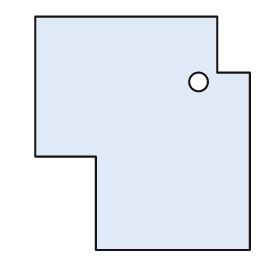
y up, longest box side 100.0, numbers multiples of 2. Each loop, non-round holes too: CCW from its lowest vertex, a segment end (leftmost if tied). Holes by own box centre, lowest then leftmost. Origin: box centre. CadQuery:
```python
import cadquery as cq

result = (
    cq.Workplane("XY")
    .moveTo(-20.0, -50.0)
    .lineTo(46.0, -50.0)
    .lineTo(46.0, 26.0)
    .lineTo(32.0, 26.0)
    .lineTo(32.0, 50.0)
    .lineTo(-46.0, 50.0)
    .lineTo(-46.0, -10.0)
    .lineTo(-20.0, -10.0)
    .close()
    .moveTo(24.0, 22.0)
    .circle(4.0)
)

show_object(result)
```